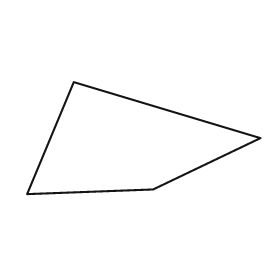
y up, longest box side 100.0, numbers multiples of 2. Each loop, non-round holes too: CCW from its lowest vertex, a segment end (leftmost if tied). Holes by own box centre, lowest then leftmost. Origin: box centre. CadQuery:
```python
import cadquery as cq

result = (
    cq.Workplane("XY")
    .moveTo(-50.0, -24.0)
    .lineTo(4.0, -22.0)
    .lineTo(50.0, 0.0)
    .lineTo(-30.0, 24.0)
    .close()
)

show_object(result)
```